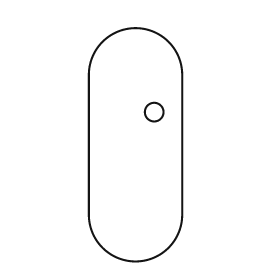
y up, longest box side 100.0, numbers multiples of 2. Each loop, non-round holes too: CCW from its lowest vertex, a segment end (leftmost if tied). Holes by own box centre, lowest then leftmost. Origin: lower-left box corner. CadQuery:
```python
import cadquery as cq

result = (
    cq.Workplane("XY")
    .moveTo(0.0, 20.0)
    .threePointArc((20.0, 0.0), (40.0, 20.0))
    .lineTo(40.0, 80.0)
    .threePointArc((20.0, 100.0), (0.0, 80.0))
    .close()
    .moveTo(28.0, 64.0)
    .circle(4.0)
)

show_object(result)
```